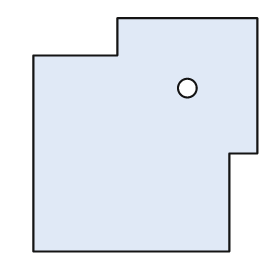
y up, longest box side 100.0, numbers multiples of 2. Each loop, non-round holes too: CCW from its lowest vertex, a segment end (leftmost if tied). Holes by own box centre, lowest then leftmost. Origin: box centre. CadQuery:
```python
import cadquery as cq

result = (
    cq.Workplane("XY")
    .moveTo(-48.0, -50.0)
    .lineTo(36.0, -50.0)
    .lineTo(36.0, -8.0)
    .lineTo(48.0, -8.0)
    .lineTo(48.0, 50.0)
    .lineTo(-12.0, 50.0)
    .lineTo(-12.0, 34.0)
    .lineTo(-48.0, 34.0)
    .close()
    .moveTo(18.0, 20.0)
    .circle(4.0)
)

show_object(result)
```